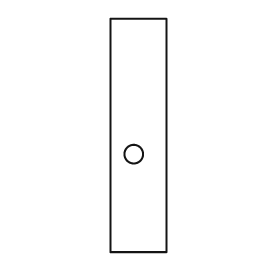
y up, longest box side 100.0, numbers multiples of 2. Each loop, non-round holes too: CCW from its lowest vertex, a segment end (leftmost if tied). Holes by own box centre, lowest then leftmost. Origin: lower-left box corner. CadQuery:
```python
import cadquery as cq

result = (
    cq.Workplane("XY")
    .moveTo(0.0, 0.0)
    .lineTo(24.0, 0.0)
    .lineTo(24.0, 100.0)
    .lineTo(0.0, 100.0)
    .close()
    .moveTo(10.0, 42.0)
    .circle(4.0)
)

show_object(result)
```